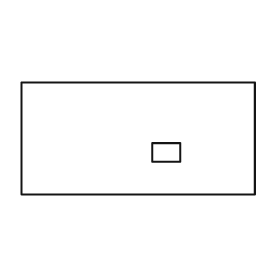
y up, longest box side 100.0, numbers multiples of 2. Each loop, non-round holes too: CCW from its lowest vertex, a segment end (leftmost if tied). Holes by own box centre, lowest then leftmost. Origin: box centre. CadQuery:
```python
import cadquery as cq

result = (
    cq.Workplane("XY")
    .moveTo(-50.0, -24.0)
    .lineTo(50.0, -24.0)
    .lineTo(50.0, 24.0)
    .lineTo(-50.0, 24.0)
    .close()
    .moveTo(6.0, -10.0)
    .lineTo(18.0, -10.0)
    .lineTo(18.0, -2.0)
    .lineTo(6.0, -2.0)
    .close()
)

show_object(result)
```